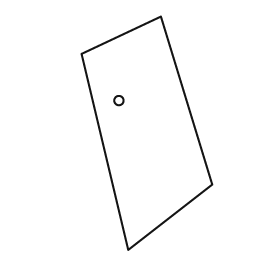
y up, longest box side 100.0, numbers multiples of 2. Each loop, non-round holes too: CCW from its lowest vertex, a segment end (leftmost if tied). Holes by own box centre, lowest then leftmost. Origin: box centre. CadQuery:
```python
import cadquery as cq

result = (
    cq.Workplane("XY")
    .moveTo(-8.0, -50.0)
    .lineTo(28.0, -22.0)
    .lineTo(6.0, 50.0)
    .lineTo(-28.0, 34.0)
    .close()
    .moveTo(-12.0, 14.0)
    .circle(2.0)
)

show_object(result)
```